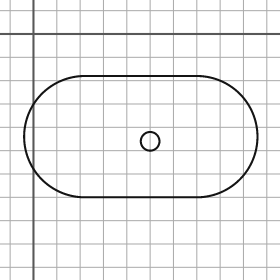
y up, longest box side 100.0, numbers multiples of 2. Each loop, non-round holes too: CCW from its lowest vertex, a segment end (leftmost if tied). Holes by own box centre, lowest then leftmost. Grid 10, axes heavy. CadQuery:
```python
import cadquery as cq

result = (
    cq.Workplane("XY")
    .moveTo(22.0, -70.0)
    .lineTo(70.0, -70.0)
    .threePointArc((96.0, -44.0), (70.0, -18.0))
    .lineTo(22.0, -18.0)
    .threePointArc((-4.0, -44.0), (22.0, -70.0))
    .close()
    .moveTo(50.0, -46.0)
    .circle(4.0)
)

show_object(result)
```